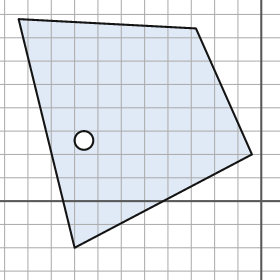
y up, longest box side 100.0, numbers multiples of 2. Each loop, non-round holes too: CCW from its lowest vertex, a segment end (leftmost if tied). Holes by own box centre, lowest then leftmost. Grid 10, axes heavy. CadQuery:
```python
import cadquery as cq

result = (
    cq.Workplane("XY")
    .moveTo(-80.0, -20.0)
    .lineTo(-4.0, 20.0)
    .lineTo(-28.0, 74.0)
    .lineTo(-104.0, 78.0)
    .close()
    .moveTo(-76.0, 26.0)
    .circle(4.0)
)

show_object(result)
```